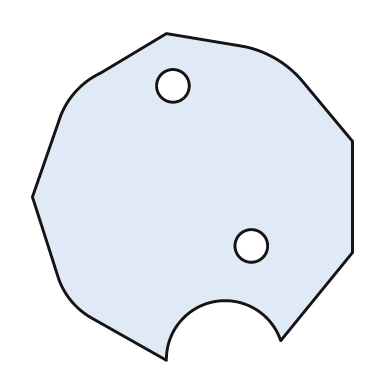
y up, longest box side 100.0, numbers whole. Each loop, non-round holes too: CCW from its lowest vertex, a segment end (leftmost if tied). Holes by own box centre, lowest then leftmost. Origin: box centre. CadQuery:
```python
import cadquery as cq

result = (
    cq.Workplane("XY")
    .moveTo(-8.0, -50.0)
    .threePointArc((7.0, -32.0), (27.0, -44.0))
    .lineTo(49.0, -17.0)
    .lineTo(49.0, 17.0)
    .lineTo(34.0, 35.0)
    .threePointArc((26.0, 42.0), (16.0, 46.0))
    .lineTo(-8.0, 50.0)
    .lineTo(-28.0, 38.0)
    .threePointArc((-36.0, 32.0), (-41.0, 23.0))
    .lineTo(-49.0, 0.0)
    .lineTo(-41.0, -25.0)
    .threePointArc((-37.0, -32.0), (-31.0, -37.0))
    .close()
    .moveTo(18.0, -15.0)
    .circle(5.0)
    .moveTo(-6.0, 34.0)
    .circle(5.0)
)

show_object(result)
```